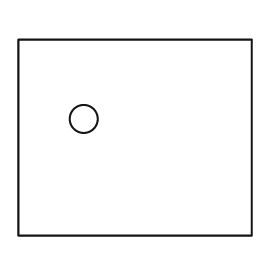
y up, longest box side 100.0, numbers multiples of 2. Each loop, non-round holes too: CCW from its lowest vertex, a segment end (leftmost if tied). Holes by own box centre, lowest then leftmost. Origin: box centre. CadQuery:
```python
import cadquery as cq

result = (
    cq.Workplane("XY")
    .moveTo(-50.0, -42.0)
    .lineTo(50.0, -42.0)
    .lineTo(50.0, 42.0)
    .lineTo(-50.0, 42.0)
    .close()
    .moveTo(-22.0, 8.0)
    .circle(6.0)
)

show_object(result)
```